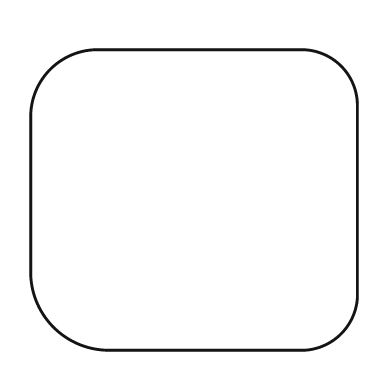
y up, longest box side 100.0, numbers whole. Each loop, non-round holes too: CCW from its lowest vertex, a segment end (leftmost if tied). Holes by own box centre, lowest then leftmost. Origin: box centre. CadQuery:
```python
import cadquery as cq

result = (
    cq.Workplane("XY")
    .moveTo(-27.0, -46.0)
    .lineTo(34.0, -46.0)
    .threePointArc((45.0, -41.0), (50.0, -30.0))
    .lineTo(50.0, 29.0)
    .threePointArc((45.0, 41.0), (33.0, 46.0))
    .lineTo(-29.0, 46.0)
    .threePointArc((-44.0, 40.0), (-50.0, 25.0))
    .lineTo(-50.0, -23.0)
    .threePointArc((-43.0, -39.0), (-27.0, -46.0))
    .close()
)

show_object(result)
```